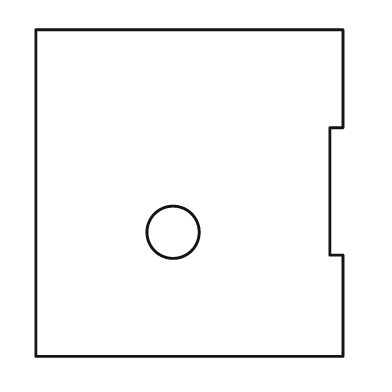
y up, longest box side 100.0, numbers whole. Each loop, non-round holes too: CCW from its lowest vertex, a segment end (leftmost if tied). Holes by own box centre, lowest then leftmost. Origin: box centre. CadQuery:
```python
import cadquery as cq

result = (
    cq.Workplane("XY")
    .moveTo(-47.0, -50.0)
    .lineTo(47.0, -50.0)
    .lineTo(47.0, -19.0)
    .lineTo(43.0, -19.0)
    .lineTo(43.0, 20.0)
    .lineTo(47.0, 20.0)
    .lineTo(47.0, 50.0)
    .lineTo(-47.0, 50.0)
    .close()
    .moveTo(-5.0, -12.0)
    .circle(8.0)
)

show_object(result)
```